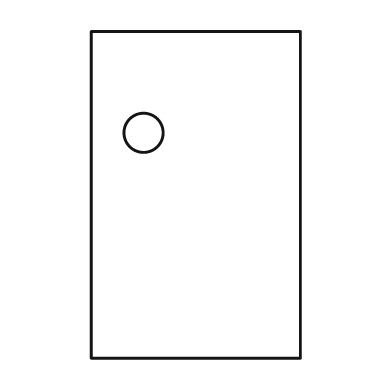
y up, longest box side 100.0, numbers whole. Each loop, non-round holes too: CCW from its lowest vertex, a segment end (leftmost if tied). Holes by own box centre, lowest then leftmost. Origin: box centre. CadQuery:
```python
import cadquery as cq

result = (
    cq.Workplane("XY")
    .moveTo(-32.0, -50.0)
    .lineTo(32.0, -50.0)
    .lineTo(32.0, 50.0)
    .lineTo(-32.0, 50.0)
    .close()
    .moveTo(-16.0, 19.0)
    .circle(6.0)
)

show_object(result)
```